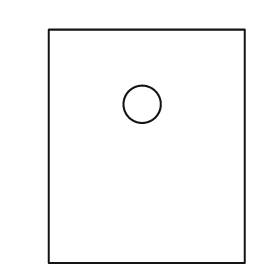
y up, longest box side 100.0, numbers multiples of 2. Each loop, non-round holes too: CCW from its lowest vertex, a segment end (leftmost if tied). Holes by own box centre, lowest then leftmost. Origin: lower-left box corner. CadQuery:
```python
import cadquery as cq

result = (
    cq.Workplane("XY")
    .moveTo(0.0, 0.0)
    .lineTo(84.0, 0.0)
    .lineTo(84.0, 100.0)
    .lineTo(0.0, 100.0)
    .close()
    .moveTo(40.0, 68.0)
    .circle(8.0)
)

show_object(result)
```